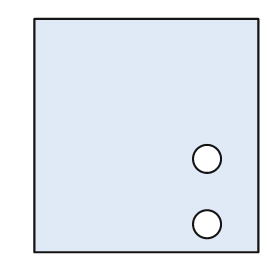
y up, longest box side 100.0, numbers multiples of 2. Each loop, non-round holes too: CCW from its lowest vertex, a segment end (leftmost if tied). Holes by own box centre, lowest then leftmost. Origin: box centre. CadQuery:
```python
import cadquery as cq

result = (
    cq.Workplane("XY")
    .moveTo(-48.0, -50.0)
    .lineTo(48.0, -50.0)
    .lineTo(48.0, 50.0)
    .lineTo(-48.0, 50.0)
    .close()
    .moveTo(26.0, -38.0)
    .circle(6.0)
    .moveTo(26.0, -10.0)
    .circle(6.0)
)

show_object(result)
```